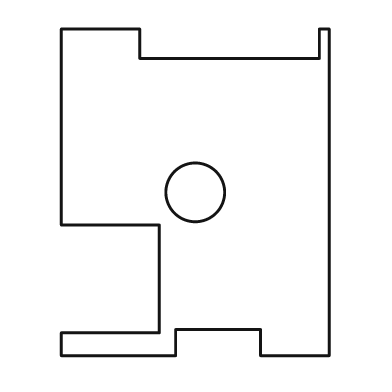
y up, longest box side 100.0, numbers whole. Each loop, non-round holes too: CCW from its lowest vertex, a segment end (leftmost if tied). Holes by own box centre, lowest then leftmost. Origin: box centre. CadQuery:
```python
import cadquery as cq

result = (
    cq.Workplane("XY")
    .moveTo(-41.0, -50.0)
    .lineTo(-6.0, -50.0)
    .lineTo(-6.0, -42.0)
    .lineTo(20.0, -42.0)
    .lineTo(20.0, -50.0)
    .lineTo(41.0, -50.0)
    .lineTo(41.0, 50.0)
    .lineTo(38.0, 50.0)
    .lineTo(38.0, 41.0)
    .lineTo(-17.0, 41.0)
    .lineTo(-17.0, 50.0)
    .lineTo(-41.0, 50.0)
    .lineTo(-41.0, -10.0)
    .lineTo(-11.0, -10.0)
    .lineTo(-11.0, -43.0)
    .lineTo(-41.0, -43.0)
    .close()
    .moveTo(0.0, 0.0)
    .circle(9.0)
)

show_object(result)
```